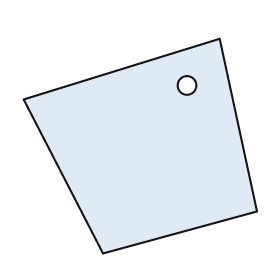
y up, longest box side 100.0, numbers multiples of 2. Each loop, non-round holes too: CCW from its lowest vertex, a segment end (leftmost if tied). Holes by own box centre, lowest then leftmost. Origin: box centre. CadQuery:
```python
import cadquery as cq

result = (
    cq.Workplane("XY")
    .moveTo(-16.0, -46.0)
    .lineTo(50.0, -28.0)
    .lineTo(34.0, 46.0)
    .lineTo(-50.0, 20.0)
    .close()
    .moveTo(20.0, 26.0)
    .circle(4.0)
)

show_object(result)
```